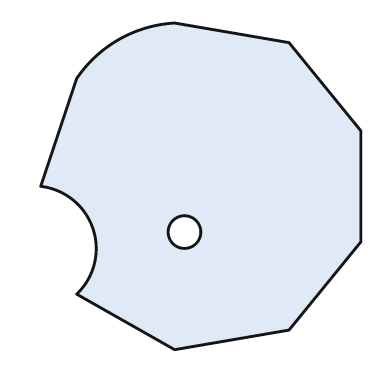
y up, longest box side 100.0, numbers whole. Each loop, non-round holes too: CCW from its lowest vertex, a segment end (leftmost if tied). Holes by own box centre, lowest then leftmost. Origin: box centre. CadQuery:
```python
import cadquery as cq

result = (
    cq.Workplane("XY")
    .moveTo(-8.0, -50.0)
    .lineTo(27.0, -44.0)
    .lineTo(49.0, -17.0)
    .lineTo(49.0, 17.0)
    .lineTo(27.0, 44.0)
    .lineTo(-8.0, 50.0)
    .threePointArc((-25.0, 45.0), (-38.0, 33.0))
    .lineTo(-49.0, 0.0)
    .threePointArc((-33.0, -13.0), (-38.0, -33.0))
    .close()
    .moveTo(-5.0, -14.0)
    .circle(5.0)
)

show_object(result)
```